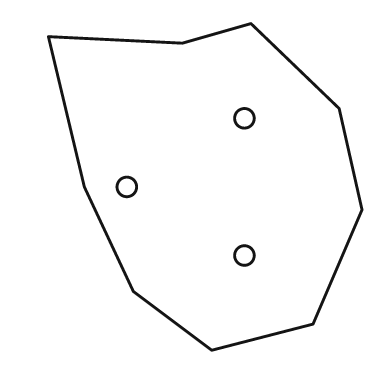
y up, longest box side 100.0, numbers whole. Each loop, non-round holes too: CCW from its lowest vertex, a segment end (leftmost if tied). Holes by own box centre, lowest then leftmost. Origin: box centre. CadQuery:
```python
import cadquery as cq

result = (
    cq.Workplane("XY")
    .moveTo(2.0, -50.0)
    .lineTo(33.0, -42.0)
    .lineTo(48.0, -7.0)
    .lineTo(41.0, 24.0)
    .lineTo(14.0, 50.0)
    .lineTo(-7.0, 44.0)
    .lineTo(-48.0, 46.0)
    .lineTo(-37.0, 0.0)
    .lineTo(-22.0, -32.0)
    .close()
    .moveTo(12.0, -21.0)
    .circle(3.0)
    .moveTo(-24.0, 0.0)
    .circle(3.0)
    .moveTo(12.0, 21.0)
    .circle(3.0)
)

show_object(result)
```